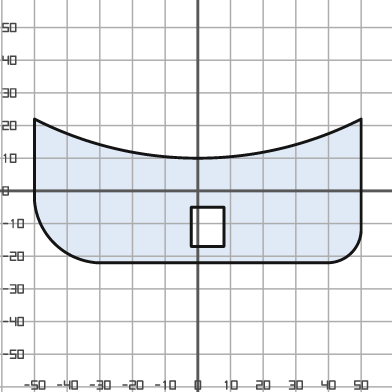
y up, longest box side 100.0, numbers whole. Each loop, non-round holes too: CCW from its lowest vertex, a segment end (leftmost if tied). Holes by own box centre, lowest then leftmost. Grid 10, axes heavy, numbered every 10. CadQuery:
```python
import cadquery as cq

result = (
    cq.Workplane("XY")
    .moveTo(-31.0, -22.0)
    .lineTo(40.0, -22.0)
    .threePointArc((47.0, -19.0), (50.0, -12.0))
    .lineTo(50.0, 22.0)
    .threePointArc((0.0, 10.0), (-50.0, 22.0))
    .lineTo(-50.0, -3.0)
    .threePointArc((-44.0, -16.0), (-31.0, -22.0))
    .close()
    .moveTo(-2.0, -17.0)
    .lineTo(8.0, -17.0)
    .lineTo(8.0, -5.0)
    .lineTo(-2.0, -5.0)
    .close()
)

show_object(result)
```